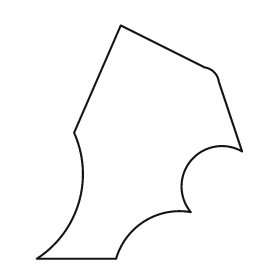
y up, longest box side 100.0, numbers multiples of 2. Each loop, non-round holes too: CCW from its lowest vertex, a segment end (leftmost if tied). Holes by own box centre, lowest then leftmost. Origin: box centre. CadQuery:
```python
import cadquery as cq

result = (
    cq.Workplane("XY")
    .moveTo(-44.0, -50.0)
    .lineTo(-10.0, -50.0)
    .threePointArc((2.0, -34.0), (22.0, -30.0))
    .threePointArc((22.0, -8.0), (44.0, -4.0))
    .lineTo(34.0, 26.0)
    .threePointArc((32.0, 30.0), (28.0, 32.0))
    .lineTo(-8.0, 50.0)
    .lineTo(-28.0, 4.0)
    .threePointArc((-26.0, -26.0), (-44.0, -50.0))
    .close()
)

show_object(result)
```